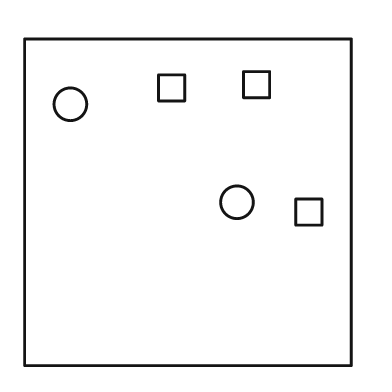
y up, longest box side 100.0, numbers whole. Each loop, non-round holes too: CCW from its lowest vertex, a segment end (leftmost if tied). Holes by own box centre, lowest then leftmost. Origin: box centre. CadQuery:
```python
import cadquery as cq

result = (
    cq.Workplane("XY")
    .moveTo(-50.0, -50.0)
    .lineTo(50.0, -50.0)
    .lineTo(50.0, 50.0)
    .lineTo(-50.0, 50.0)
    .close()
    .moveTo(33.0, -7.0)
    .lineTo(41.0, -7.0)
    .lineTo(41.0, 1.0)
    .lineTo(33.0, 1.0)
    .close()
    .moveTo(15.0, 0.0)
    .circle(5.0)
    .moveTo(-36.0, 30.0)
    .circle(5.0)
    .moveTo(-9.0, 31.0)
    .lineTo(-1.0, 31.0)
    .lineTo(-1.0, 39.0)
    .lineTo(-9.0, 39.0)
    .close()
    .moveTo(17.0, 32.0)
    .lineTo(25.0, 32.0)
    .lineTo(25.0, 40.0)
    .lineTo(17.0, 40.0)
    .close()
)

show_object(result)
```